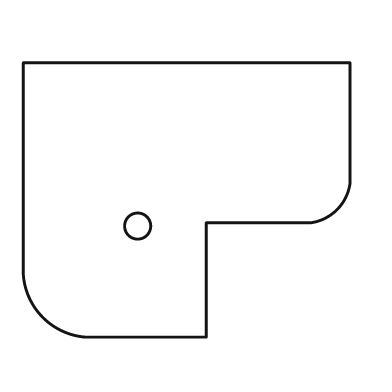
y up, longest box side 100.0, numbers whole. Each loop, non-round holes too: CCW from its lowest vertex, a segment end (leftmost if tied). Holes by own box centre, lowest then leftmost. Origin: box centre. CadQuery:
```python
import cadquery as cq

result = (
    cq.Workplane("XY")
    .moveTo(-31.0, -42.0)
    .lineTo(6.0, -42.0)
    .lineTo(6.0, -7.0)
    .lineTo(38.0, -7.0)
    .threePointArc((46.0, -3.0), (50.0, 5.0))
    .lineTo(50.0, 42.0)
    .lineTo(-50.0, 42.0)
    .lineTo(-50.0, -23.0)
    .threePointArc((-44.0, -36.0), (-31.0, -42.0))
    .close()
    .moveTo(-15.0, -8.0)
    .circle(4.0)
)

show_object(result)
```